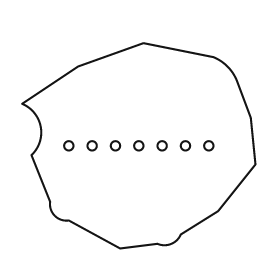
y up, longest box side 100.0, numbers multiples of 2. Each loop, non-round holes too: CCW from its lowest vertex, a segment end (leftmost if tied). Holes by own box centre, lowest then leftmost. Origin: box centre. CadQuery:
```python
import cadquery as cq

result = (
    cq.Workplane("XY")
    .moveTo(-8.0, -44.0)
    .lineTo(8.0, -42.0)
    .threePointArc((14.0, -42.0), (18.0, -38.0))
    .lineTo(34.0, -28.0)
    .lineTo(50.0, -8.0)
    .lineTo(48.0, 12.0)
    .lineTo(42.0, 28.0)
    .threePointArc((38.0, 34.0), (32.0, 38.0))
    .lineTo(2.0, 44.0)
    .lineTo(-26.0, 34.0)
    .lineTo(-50.0, 18.0)
    .threePointArc((-42.0, 8.0), (-46.0, -4.0))
    .lineTo(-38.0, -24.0)
    .threePointArc((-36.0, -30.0), (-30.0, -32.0))
    .close()
    .moveTo(-30.0, 0.0)
    .circle(2.0)
    .moveTo(-20.0, 0.0)
    .circle(2.0)
    .moveTo(-10.0, 0.0)
    .circle(2.0)
    .moveTo(0.0, 0.0)
    .circle(2.0)
    .moveTo(10.0, 0.0)
    .circle(2.0)
    .moveTo(20.0, 0.0)
    .circle(2.0)
    .moveTo(30.0, 0.0)
    .circle(2.0)
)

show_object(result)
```